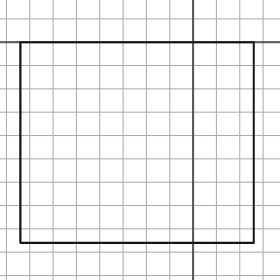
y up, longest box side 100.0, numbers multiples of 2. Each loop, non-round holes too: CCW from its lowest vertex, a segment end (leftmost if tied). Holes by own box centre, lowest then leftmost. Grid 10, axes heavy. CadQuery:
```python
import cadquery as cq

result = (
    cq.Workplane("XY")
    .moveTo(-74.0, -86.0)
    .lineTo(26.0, -86.0)
    .lineTo(26.0, 0.0)
    .lineTo(-74.0, 0.0)
    .close()
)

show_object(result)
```